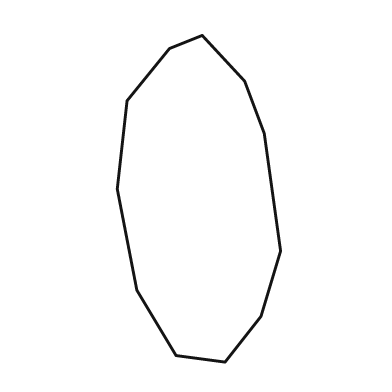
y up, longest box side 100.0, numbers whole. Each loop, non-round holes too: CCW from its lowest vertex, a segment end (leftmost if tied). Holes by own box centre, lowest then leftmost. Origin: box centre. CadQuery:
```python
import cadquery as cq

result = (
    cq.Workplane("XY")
    .moveTo(8.0, -50.0)
    .lineTo(19.0, -36.0)
    .lineTo(25.0, -16.0)
    .lineTo(20.0, 20.0)
    .lineTo(14.0, 36.0)
    .lineTo(1.0, 50.0)
    .lineTo(-9.0, 46.0)
    .lineTo(-22.0, 30.0)
    .lineTo(-25.0, 3.0)
    .lineTo(-19.0, -28.0)
    .lineTo(-7.0, -48.0)
    .close()
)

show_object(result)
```